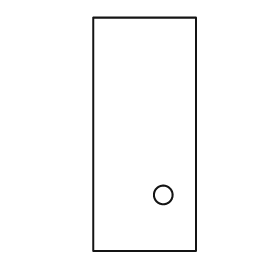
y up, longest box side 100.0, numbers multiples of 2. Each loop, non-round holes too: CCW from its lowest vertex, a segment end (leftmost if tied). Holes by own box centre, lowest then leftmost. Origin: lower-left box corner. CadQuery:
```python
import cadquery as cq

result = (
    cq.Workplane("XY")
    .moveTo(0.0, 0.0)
    .lineTo(44.0, 0.0)
    .lineTo(44.0, 100.0)
    .lineTo(0.0, 100.0)
    .close()
    .moveTo(30.0, 24.0)
    .circle(4.0)
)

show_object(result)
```